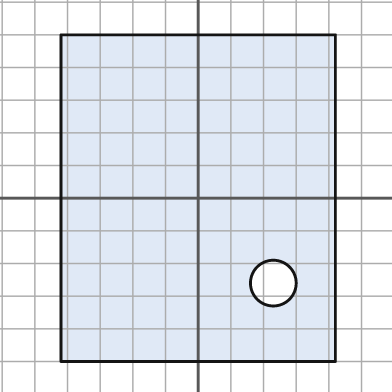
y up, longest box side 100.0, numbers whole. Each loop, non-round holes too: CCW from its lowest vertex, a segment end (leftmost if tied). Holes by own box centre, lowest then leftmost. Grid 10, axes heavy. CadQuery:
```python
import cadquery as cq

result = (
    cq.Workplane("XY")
    .moveTo(-42.0, -50.0)
    .lineTo(42.0, -50.0)
    .lineTo(42.0, 50.0)
    .lineTo(-42.0, 50.0)
    .close()
    .moveTo(23.0, -26.0)
    .circle(7.0)
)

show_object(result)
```